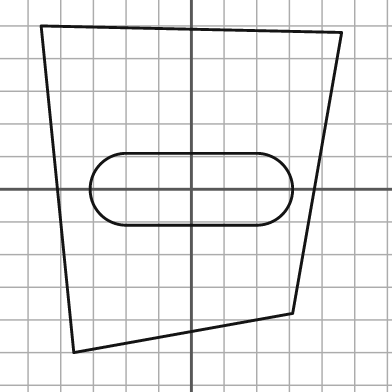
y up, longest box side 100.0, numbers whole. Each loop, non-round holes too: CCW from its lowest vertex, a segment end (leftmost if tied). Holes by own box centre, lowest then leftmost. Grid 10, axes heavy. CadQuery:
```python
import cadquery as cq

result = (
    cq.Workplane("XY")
    .moveTo(-36.0, -50.0)
    .lineTo(31.0, -38.0)
    .lineTo(46.0, 48.0)
    .lineTo(-46.0, 50.0)
    .close()
    .moveTo(-20.0, -11.0)
    .lineTo(20.0, -11.0)
    .threePointArc((31.0, 0.0), (20.0, 11.0))
    .lineTo(-20.0, 11.0)
    .threePointArc((-31.0, 0.0), (-20.0, -11.0))
    .close()
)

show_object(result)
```